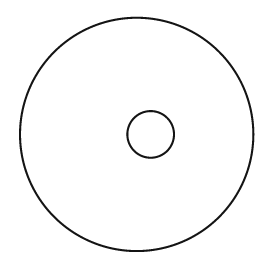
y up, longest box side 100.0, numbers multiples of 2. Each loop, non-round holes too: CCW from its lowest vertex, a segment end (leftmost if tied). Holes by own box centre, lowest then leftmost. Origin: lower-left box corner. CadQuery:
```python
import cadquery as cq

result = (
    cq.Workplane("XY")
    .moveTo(50.0, 50.0)
    .circle(50.0)
    .moveTo(56.0, 50.0)
    .circle(10.0)
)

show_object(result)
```